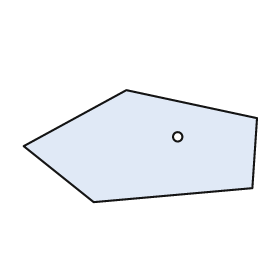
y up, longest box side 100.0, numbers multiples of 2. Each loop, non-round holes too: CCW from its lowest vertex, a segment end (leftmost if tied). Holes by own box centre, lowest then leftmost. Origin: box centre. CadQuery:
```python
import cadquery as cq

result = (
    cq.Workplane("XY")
    .moveTo(-20.0, -24.0)
    .lineTo(48.0, -18.0)
    .lineTo(50.0, 12.0)
    .lineTo(-6.0, 24.0)
    .lineTo(-50.0, 0.0)
    .close()
    .moveTo(16.0, 4.0)
    .circle(2.0)
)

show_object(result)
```